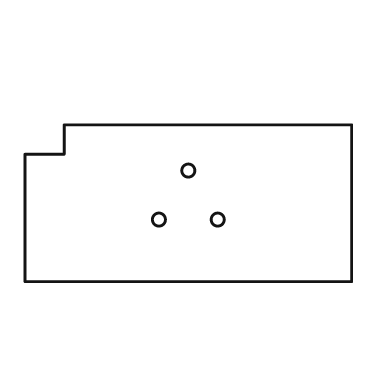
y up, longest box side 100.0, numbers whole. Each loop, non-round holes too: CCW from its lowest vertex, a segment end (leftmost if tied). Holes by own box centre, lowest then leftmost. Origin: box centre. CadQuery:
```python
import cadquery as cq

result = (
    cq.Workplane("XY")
    .moveTo(-50.0, -24.0)
    .lineTo(50.0, -24.0)
    .lineTo(50.0, 24.0)
    .lineTo(-38.0, 24.0)
    .lineTo(-38.0, 15.0)
    .lineTo(-50.0, 15.0)
    .close()
    .moveTo(-9.0, -5.0)
    .circle(2.0)
    .moveTo(9.0, -5.0)
    .circle(2.0)
    .moveTo(0.0, 10.0)
    .circle(2.0)
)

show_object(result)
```